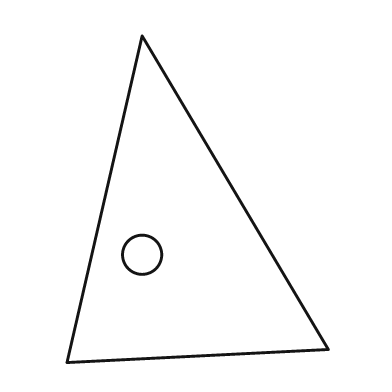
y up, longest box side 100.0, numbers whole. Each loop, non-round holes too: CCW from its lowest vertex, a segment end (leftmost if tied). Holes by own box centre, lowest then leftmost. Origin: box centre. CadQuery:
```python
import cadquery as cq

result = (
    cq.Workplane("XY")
    .moveTo(-40.0, -50.0)
    .lineTo(40.0, -46.0)
    .lineTo(-17.0, 50.0)
    .close()
    .moveTo(-17.0, -17.0)
    .circle(6.0)
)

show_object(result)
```